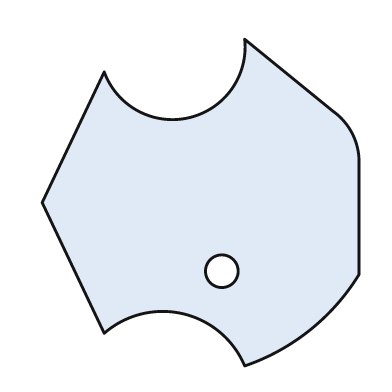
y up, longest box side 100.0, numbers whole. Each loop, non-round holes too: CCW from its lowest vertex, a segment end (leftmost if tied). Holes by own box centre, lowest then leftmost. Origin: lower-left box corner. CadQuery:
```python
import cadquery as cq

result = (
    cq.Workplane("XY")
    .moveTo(62.0, 0.0)
    .threePointArc((82.0, 11.0), (97.0, 28.0))
    .lineTo(97.0, 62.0)
    .threePointArc((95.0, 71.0), (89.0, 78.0))
    .lineTo(62.0, 100.0)
    .threePointArc((45.0, 76.0), (19.0, 90.0))
    .lineTo(0.0, 50.0)
    .lineTo(19.0, 10.0)
    .threePointArc((43.0, 16.0), (62.0, 0.0))
    .close()
    .moveTo(55.0, 29.0)
    .circle(5.0)
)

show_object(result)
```